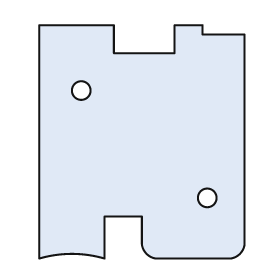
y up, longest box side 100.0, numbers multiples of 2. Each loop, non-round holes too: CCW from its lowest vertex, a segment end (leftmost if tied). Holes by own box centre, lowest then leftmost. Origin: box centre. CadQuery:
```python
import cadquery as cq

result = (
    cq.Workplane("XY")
    .moveTo(-44.0, -50.0)
    .threePointArc((-30.0, -48.0), (-16.0, -50.0))
    .lineTo(-16.0, -32.0)
    .lineTo(0.0, -32.0)
    .lineTo(0.0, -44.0)
    .threePointArc((2.0, -48.0), (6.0, -50.0))
    .lineTo(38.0, -50.0)
    .threePointArc((42.0, -48.0), (44.0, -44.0))
    .lineTo(44.0, 46.0)
    .lineTo(26.0, 46.0)
    .lineTo(26.0, 50.0)
    .lineTo(14.0, 50.0)
    .lineTo(14.0, 38.0)
    .lineTo(-12.0, 38.0)
    .lineTo(-12.0, 50.0)
    .lineTo(-44.0, 50.0)
    .close()
    .moveTo(28.0, -24.0)
    .circle(4.0)
    .moveTo(-26.0, 22.0)
    .circle(4.0)
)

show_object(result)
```